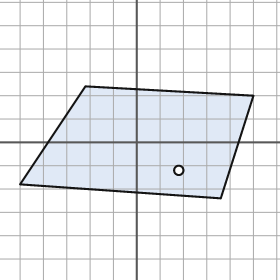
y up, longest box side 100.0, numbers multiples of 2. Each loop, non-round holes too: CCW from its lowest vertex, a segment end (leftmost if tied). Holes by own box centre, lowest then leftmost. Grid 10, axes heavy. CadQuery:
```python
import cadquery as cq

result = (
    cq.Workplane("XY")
    .moveTo(36.0, -24.0)
    .lineTo(50.0, 20.0)
    .lineTo(-22.0, 24.0)
    .lineTo(-50.0, -18.0)
    .close()
    .moveTo(18.0, -12.0)
    .circle(2.0)
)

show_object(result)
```